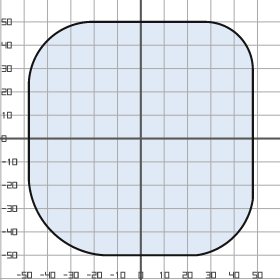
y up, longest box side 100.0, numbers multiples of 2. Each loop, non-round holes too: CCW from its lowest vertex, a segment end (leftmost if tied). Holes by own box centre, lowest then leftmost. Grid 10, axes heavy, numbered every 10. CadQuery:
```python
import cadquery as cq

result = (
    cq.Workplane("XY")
    .moveTo(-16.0, -50.0)
    .lineTo(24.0, -50.0)
    .threePointArc((40.0, -42.0), (48.0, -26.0))
    .lineTo(48.0, 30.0)
    .threePointArc((42.0, 44.0), (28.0, 50.0))
    .lineTo(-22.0, 50.0)
    .threePointArc((-40.0, 42.0), (-48.0, 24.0))
    .lineTo(-48.0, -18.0)
    .threePointArc((-38.0, -40.0), (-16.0, -50.0))
    .close()
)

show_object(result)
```